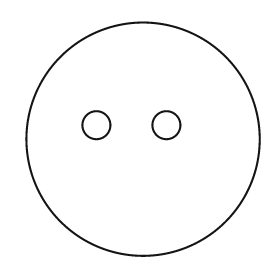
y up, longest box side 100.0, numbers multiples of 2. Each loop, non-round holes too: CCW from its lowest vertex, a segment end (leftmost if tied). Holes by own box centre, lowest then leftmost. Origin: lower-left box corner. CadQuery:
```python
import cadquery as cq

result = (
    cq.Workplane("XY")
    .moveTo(50.0, 50.0)
    .circle(50.0)
    .moveTo(30.0, 56.0)
    .circle(6.0)
    .moveTo(60.0, 56.0)
    .circle(6.0)
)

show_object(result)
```